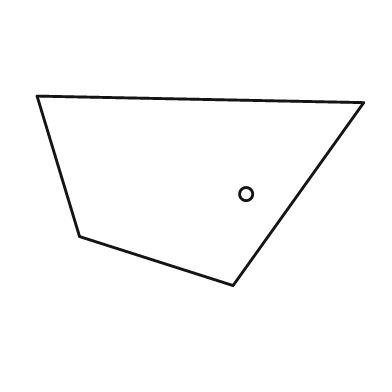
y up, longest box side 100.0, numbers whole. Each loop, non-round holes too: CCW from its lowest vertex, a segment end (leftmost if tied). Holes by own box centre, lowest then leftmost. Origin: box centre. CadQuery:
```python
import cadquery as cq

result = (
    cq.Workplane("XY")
    .moveTo(10.0, -29.0)
    .lineTo(50.0, 27.0)
    .lineTo(-50.0, 29.0)
    .lineTo(-37.0, -14.0)
    .close()
    .moveTo(14.0, -1.0)
    .circle(2.0)
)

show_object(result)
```